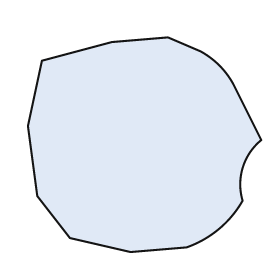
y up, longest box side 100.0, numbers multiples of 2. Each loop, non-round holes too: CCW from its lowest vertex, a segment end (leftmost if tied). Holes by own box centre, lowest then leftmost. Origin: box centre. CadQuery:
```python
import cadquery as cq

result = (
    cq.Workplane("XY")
    .moveTo(-6.0, -46.0)
    .lineTo(18.0, -44.0)
    .threePointArc((32.0, -36.0), (42.0, -24.0))
    .threePointArc((42.0, -10.0), (50.0, 2.0))
    .lineTo(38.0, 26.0)
    .threePointArc((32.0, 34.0), (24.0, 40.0))
    .lineTo(10.0, 46.0)
    .lineTo(-14.0, 44.0)
    .lineTo(-44.0, 36.0)
    .lineTo(-50.0, 8.0)
    .lineTo(-46.0, -22.0)
    .lineTo(-32.0, -40.0)
    .close()
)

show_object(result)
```